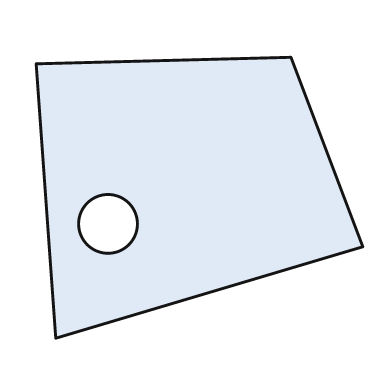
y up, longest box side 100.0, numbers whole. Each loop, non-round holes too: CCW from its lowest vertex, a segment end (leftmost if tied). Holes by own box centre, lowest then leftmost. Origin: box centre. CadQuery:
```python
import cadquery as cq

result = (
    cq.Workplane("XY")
    .moveTo(-44.0, -43.0)
    .lineTo(50.0, -15.0)
    .lineTo(28.0, 43.0)
    .lineTo(-50.0, 41.0)
    .close()
    .moveTo(-28.0, -8.0)
    .circle(9.0)
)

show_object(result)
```